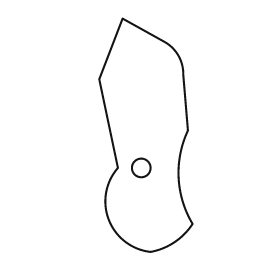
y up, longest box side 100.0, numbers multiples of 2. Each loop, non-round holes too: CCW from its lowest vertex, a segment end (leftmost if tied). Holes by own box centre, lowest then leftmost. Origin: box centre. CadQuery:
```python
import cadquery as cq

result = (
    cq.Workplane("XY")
    .moveTo(2.0, -50.0)
    .threePointArc((12.0, -46.0), (20.0, -38.0))
    .threePointArc((14.0, -18.0), (18.0, 2.0))
    .lineTo(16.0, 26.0)
    .threePointArc((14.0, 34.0), (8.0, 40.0))
    .lineTo(-10.0, 50.0)
    .lineTo(-20.0, 24.0)
    .lineTo(-12.0, -14.0)
    .threePointArc((-16.0, -36.0), (2.0, -50.0))
    .close()
    .moveTo(-2.0, -14.0)
    .circle(4.0)
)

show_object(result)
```